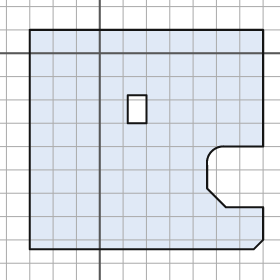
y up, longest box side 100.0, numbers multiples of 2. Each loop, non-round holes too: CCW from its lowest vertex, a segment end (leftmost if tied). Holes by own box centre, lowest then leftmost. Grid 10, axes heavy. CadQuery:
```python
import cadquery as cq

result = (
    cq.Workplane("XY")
    .moveTo(-30.0, -84.0)
    .lineTo(66.0, -84.0)
    .lineTo(70.0, -80.0)
    .lineTo(70.0, -66.0)
    .lineTo(54.0, -66.0)
    .lineTo(46.0, -58.0)
    .lineTo(46.0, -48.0)
    .threePointArc((48.0, -42.0), (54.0, -40.0))
    .lineTo(70.0, -40.0)
    .lineTo(70.0, 10.0)
    .lineTo(-30.0, 10.0)
    .close()
    .moveTo(12.0, -30.0)
    .lineTo(20.0, -30.0)
    .lineTo(20.0, -18.0)
    .lineTo(12.0, -18.0)
    .close()
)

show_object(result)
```